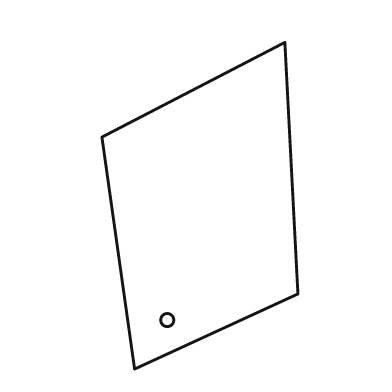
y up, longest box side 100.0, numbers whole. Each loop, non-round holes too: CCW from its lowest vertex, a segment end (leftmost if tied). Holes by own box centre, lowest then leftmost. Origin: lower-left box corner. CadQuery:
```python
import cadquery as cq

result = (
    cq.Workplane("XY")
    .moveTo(10.0, 0.0)
    .lineTo(60.0, 23.0)
    .lineTo(56.0, 100.0)
    .lineTo(0.0, 71.0)
    .close()
    .moveTo(20.0, 15.0)
    .circle(2.0)
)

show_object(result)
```